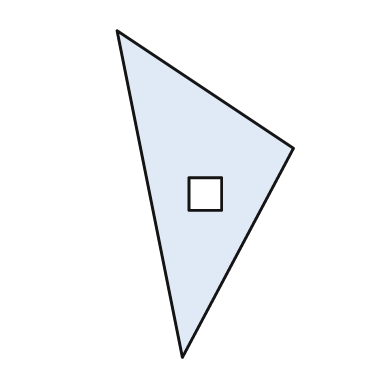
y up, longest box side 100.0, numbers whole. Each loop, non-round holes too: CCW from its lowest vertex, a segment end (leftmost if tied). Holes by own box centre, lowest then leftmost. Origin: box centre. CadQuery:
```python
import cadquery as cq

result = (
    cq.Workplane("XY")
    .moveTo(-7.0, -50.0)
    .lineTo(27.0, 14.0)
    .lineTo(-27.0, 50.0)
    .close()
    .moveTo(-5.0, -5.0)
    .lineTo(5.0, -5.0)
    .lineTo(5.0, 5.0)
    .lineTo(-5.0, 5.0)
    .close()
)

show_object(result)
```